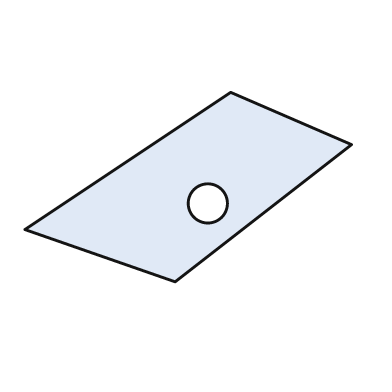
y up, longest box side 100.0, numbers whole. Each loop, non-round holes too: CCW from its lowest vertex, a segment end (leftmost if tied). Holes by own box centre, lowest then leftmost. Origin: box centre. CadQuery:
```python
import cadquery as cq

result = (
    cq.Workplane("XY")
    .moveTo(-4.0, -29.0)
    .lineTo(50.0, 13.0)
    .lineTo(13.0, 29.0)
    .lineTo(-50.0, -13.0)
    .close()
    .moveTo(6.0, -5.0)
    .circle(6.0)
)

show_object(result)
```